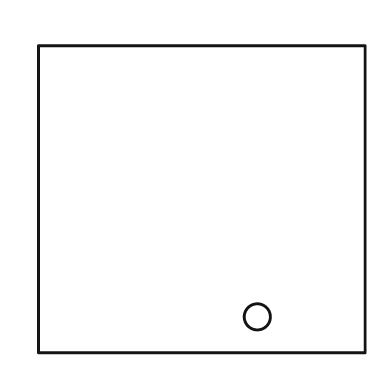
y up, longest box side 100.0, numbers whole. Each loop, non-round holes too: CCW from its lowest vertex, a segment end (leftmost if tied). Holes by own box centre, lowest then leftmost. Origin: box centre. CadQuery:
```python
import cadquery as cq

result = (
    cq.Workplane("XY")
    .moveTo(-50.0, -47.0)
    .lineTo(50.0, -47.0)
    .lineTo(50.0, 47.0)
    .lineTo(-50.0, 47.0)
    .close()
    .moveTo(17.0, -36.0)
    .circle(4.0)
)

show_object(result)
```